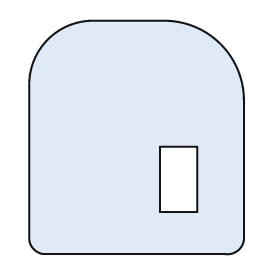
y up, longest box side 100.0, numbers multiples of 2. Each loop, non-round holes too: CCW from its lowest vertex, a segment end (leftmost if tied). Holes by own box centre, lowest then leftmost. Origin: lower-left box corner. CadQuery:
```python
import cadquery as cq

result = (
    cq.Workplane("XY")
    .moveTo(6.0, 0.0)
    .lineTo(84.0, 0.0)
    .threePointArc((90.0, 2.0), (92.0, 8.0))
    .lineTo(92.0, 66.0)
    .threePointArc((82.0, 90.0), (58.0, 100.0))
    .lineTo(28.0, 100.0)
    .threePointArc((8.0, 92.0), (0.0, 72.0))
    .lineTo(0.0, 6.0)
    .threePointArc((2.0, 2.0), (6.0, 0.0))
    .close()
    .moveTo(56.0, 18.0)
    .lineTo(72.0, 18.0)
    .lineTo(72.0, 46.0)
    .lineTo(56.0, 46.0)
    .close()
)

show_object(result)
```